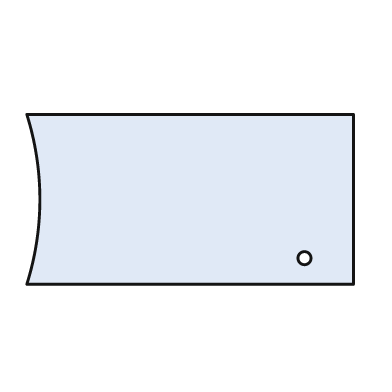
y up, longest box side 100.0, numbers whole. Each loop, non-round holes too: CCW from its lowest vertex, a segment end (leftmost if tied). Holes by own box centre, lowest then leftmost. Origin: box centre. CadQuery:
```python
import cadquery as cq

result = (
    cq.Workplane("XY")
    .moveTo(-50.0, -26.0)
    .lineTo(50.0, -26.0)
    .lineTo(50.0, 26.0)
    .lineTo(-50.0, 26.0)
    .threePointArc((-46.0, 0.0), (-50.0, -26.0))
    .close()
    .moveTo(35.0, -18.0)
    .circle(2.0)
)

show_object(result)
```